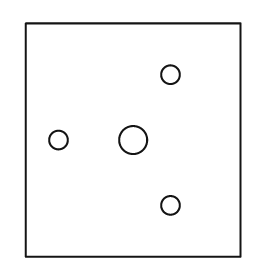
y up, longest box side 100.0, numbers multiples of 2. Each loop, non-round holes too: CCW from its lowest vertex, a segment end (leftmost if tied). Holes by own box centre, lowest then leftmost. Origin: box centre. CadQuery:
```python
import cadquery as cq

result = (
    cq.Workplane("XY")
    .moveTo(-46.0, -50.0)
    .lineTo(46.0, -50.0)
    .lineTo(46.0, 50.0)
    .lineTo(-46.0, 50.0)
    .close()
    .moveTo(16.0, -28.0)
    .circle(4.0)
    .moveTo(-32.0, 0.0)
    .circle(4.0)
    .moveTo(0.0, 0.0)
    .circle(6.0)
    .moveTo(16.0, 28.0)
    .circle(4.0)
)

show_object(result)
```